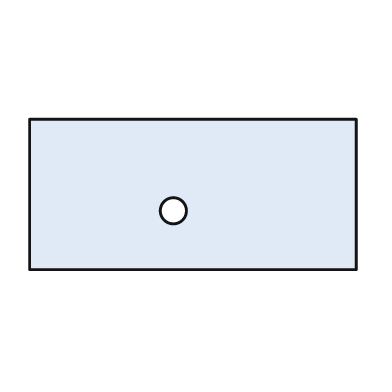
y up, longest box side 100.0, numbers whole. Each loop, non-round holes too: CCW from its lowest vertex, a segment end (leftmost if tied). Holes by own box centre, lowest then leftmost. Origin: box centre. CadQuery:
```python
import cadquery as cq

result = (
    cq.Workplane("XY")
    .moveTo(-50.0, -23.0)
    .lineTo(50.0, -23.0)
    .lineTo(50.0, 23.0)
    .lineTo(-50.0, 23.0)
    .close()
    .moveTo(-6.0, -5.0)
    .circle(4.0)
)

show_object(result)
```